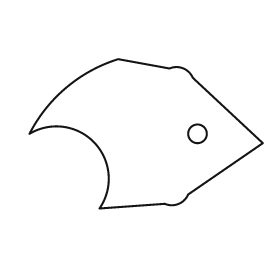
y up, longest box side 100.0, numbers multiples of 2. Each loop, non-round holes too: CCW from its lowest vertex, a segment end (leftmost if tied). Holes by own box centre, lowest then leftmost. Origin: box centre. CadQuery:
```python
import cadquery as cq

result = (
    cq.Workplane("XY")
    .moveTo(-20.0, -32.0)
    .lineTo(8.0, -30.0)
    .threePointArc((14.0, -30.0), (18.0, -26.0))
    .lineTo(50.0, -4.0)
    .lineTo(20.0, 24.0)
    .threePointArc((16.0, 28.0), (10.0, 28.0))
    .lineTo(-12.0, 32.0)
    .threePointArc((-34.0, 20.0), (-50.0, 0.0))
    .threePointArc((-22.0, -4.0), (-20.0, -32.0))
    .close()
    .moveTo(22.0, 0.0)
    .circle(4.0)
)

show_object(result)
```